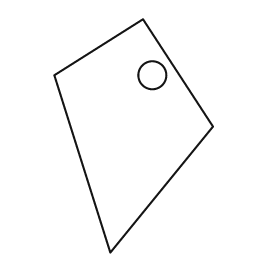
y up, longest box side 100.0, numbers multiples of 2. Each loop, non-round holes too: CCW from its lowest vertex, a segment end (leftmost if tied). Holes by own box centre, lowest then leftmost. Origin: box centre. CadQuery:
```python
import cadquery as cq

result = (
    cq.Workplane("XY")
    .moveTo(-10.0, -50.0)
    .lineTo(34.0, 4.0)
    .lineTo(4.0, 50.0)
    .lineTo(-34.0, 26.0)
    .close()
    .moveTo(8.0, 26.0)
    .circle(6.0)
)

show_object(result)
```